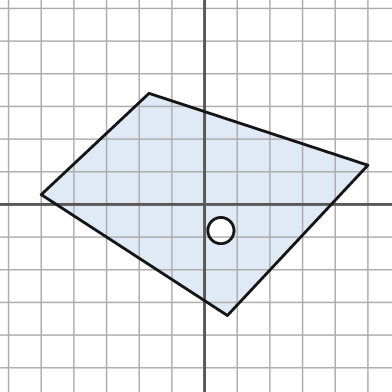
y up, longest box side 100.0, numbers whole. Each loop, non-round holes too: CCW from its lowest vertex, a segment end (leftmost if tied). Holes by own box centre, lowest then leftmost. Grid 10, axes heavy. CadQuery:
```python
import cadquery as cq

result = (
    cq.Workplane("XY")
    .moveTo(7.0, -34.0)
    .lineTo(50.0, 12.0)
    .lineTo(-17.0, 34.0)
    .lineTo(-50.0, 3.0)
    .close()
    .moveTo(5.0, -8.0)
    .circle(4.0)
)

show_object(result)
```